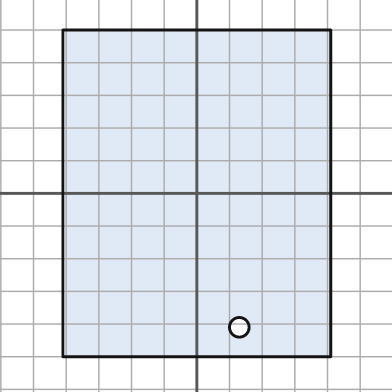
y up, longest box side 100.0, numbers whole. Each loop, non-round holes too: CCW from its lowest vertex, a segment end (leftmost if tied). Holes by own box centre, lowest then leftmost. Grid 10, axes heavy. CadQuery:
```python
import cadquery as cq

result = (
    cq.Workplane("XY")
    .moveTo(-41.0, -50.0)
    .lineTo(41.0, -50.0)
    .lineTo(41.0, 50.0)
    .lineTo(-41.0, 50.0)
    .close()
    .moveTo(13.0, -41.0)
    .circle(3.0)
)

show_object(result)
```